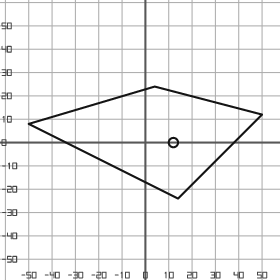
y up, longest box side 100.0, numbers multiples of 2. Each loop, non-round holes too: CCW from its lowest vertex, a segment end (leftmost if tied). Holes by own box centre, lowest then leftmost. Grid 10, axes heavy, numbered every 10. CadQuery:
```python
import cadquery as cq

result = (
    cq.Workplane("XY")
    .moveTo(14.0, -24.0)
    .lineTo(50.0, 12.0)
    .lineTo(4.0, 24.0)
    .lineTo(-50.0, 8.0)
    .close()
    .moveTo(12.0, 0.0)
    .circle(2.0)
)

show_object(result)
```